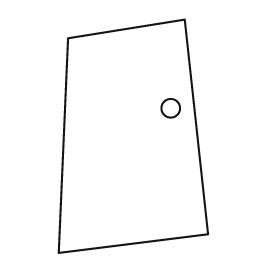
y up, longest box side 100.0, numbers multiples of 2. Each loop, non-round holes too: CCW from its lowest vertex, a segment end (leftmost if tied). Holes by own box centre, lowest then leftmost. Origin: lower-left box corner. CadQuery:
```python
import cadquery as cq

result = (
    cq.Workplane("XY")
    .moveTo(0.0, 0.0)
    .lineTo(64.0, 8.0)
    .lineTo(54.0, 100.0)
    .lineTo(4.0, 92.0)
    .close()
    .moveTo(48.0, 62.0)
    .circle(4.0)
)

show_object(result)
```